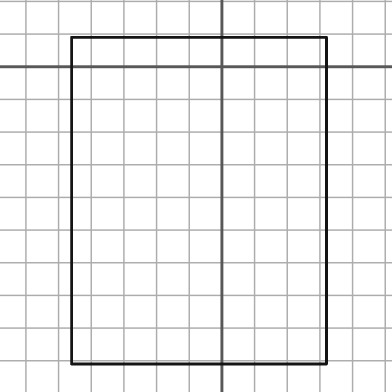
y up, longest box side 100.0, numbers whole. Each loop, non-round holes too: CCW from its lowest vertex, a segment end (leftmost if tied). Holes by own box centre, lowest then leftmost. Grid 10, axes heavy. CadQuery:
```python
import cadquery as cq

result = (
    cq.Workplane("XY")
    .moveTo(-46.0, -91.0)
    .lineTo(32.0, -91.0)
    .lineTo(32.0, 9.0)
    .lineTo(-46.0, 9.0)
    .close()
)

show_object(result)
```